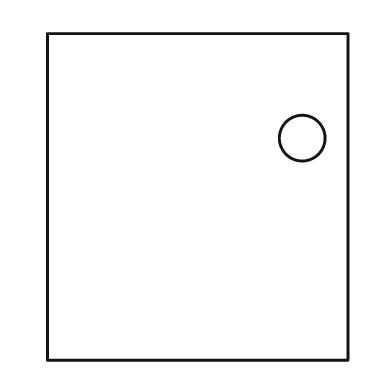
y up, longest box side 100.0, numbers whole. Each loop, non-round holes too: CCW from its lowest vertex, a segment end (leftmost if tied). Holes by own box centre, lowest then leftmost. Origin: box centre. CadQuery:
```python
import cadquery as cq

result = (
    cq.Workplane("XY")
    .moveTo(-46.0, -50.0)
    .lineTo(46.0, -50.0)
    .lineTo(46.0, 50.0)
    .lineTo(-46.0, 50.0)
    .close()
    .moveTo(32.0, 18.0)
    .circle(7.0)
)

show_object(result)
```